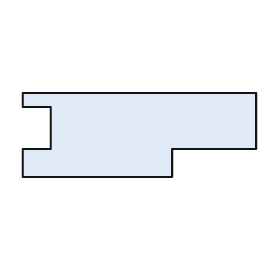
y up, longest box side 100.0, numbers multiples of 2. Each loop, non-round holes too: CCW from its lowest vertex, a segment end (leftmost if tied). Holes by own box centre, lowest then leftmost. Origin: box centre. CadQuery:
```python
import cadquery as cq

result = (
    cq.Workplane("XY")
    .moveTo(-50.0, -18.0)
    .lineTo(14.0, -18.0)
    .lineTo(14.0, -6.0)
    .lineTo(50.0, -6.0)
    .lineTo(50.0, 18.0)
    .lineTo(-50.0, 18.0)
    .lineTo(-50.0, 12.0)
    .lineTo(-38.0, 12.0)
    .lineTo(-38.0, -6.0)
    .lineTo(-50.0, -6.0)
    .close()
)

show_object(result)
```